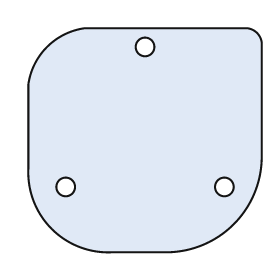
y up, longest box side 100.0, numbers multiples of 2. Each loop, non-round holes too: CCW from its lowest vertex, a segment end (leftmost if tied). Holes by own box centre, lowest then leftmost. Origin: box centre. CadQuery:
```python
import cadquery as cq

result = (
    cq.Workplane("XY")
    .moveTo(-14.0, -48.0)
    .lineTo(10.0, -48.0)
    .threePointArc((38.0, -36.0), (50.0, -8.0))
    .lineTo(50.0, 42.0)
    .threePointArc((48.0, 46.0), (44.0, 48.0))
    .lineTo(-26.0, 48.0)
    .threePointArc((-42.0, 40.0), (-50.0, 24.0))
    .lineTo(-50.0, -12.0)
    .threePointArc((-40.0, -38.0), (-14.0, -48.0))
    .close()
    .moveTo(-34.0, -20.0)
    .circle(4.0)
    .moveTo(34.0, -20.0)
    .circle(4.0)
    .moveTo(0.0, 40.0)
    .circle(4.0)
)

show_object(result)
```